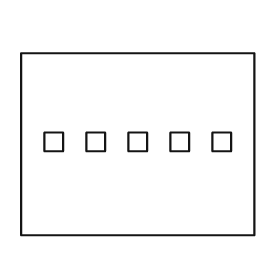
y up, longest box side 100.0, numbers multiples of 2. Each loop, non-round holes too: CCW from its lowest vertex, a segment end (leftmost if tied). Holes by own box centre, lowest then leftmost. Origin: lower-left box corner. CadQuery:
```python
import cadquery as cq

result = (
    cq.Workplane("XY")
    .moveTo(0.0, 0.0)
    .lineTo(100.0, 0.0)
    .lineTo(100.0, 78.0)
    .lineTo(0.0, 78.0)
    .close()
    .moveTo(10.0, 36.0)
    .lineTo(18.0, 36.0)
    .lineTo(18.0, 44.0)
    .lineTo(10.0, 44.0)
    .close()
    .moveTo(28.0, 36.0)
    .lineTo(36.0, 36.0)
    .lineTo(36.0, 44.0)
    .lineTo(28.0, 44.0)
    .close()
    .moveTo(46.0, 36.0)
    .lineTo(54.0, 36.0)
    .lineTo(54.0, 44.0)
    .lineTo(46.0, 44.0)
    .close()
    .moveTo(64.0, 36.0)
    .lineTo(72.0, 36.0)
    .lineTo(72.0, 44.0)
    .lineTo(64.0, 44.0)
    .close()
    .moveTo(82.0, 36.0)
    .lineTo(90.0, 36.0)
    .lineTo(90.0, 44.0)
    .lineTo(82.0, 44.0)
    .close()
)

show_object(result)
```